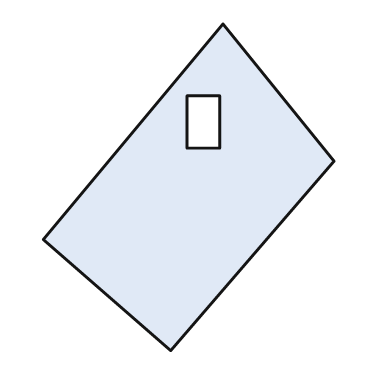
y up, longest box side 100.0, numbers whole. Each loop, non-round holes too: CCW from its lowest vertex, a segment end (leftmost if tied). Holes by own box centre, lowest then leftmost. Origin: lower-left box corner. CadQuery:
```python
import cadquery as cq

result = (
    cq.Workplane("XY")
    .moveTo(39.0, 0.0)
    .lineTo(89.0, 58.0)
    .lineTo(55.0, 100.0)
    .lineTo(0.0, 34.0)
    .close()
    .moveTo(44.0, 62.0)
    .lineTo(54.0, 62.0)
    .lineTo(54.0, 78.0)
    .lineTo(44.0, 78.0)
    .close()
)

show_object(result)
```